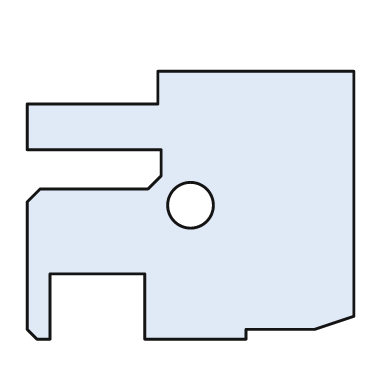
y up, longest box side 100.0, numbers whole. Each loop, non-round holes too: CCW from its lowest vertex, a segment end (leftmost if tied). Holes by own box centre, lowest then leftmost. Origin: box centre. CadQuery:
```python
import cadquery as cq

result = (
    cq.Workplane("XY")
    .moveTo(-47.0, -41.0)
    .lineTo(-43.0, -41.0)
    .lineTo(-43.0, -21.0)
    .lineTo(-14.0, -21.0)
    .lineTo(-14.0, -41.0)
    .lineTo(17.0, -41.0)
    .lineTo(17.0, -38.0)
    .lineTo(38.0, -38.0)
    .lineTo(50.0, -34.0)
    .lineTo(50.0, 41.0)
    .lineTo(-10.0, 41.0)
    .lineTo(-10.0, 31.0)
    .lineTo(-50.0, 31.0)
    .lineTo(-50.0, 17.0)
    .lineTo(-9.0, 17.0)
    .lineTo(-9.0, 9.0)
    .lineTo(-13.0, 5.0)
    .lineTo(-46.0, 5.0)
    .lineTo(-50.0, 1.0)
    .lineTo(-50.0, -38.0)
    .close()
    .moveTo(0.0, 0.0)
    .circle(7.0)
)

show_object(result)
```